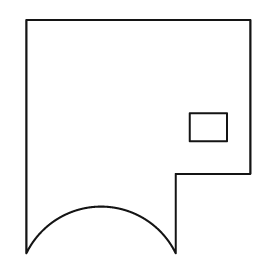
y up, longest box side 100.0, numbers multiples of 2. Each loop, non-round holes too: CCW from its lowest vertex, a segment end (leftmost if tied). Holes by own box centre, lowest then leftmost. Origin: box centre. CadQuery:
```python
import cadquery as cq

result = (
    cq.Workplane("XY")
    .moveTo(-48.0, -50.0)
    .threePointArc((-16.0, -30.0), (16.0, -50.0))
    .lineTo(16.0, -16.0)
    .lineTo(48.0, -16.0)
    .lineTo(48.0, 50.0)
    .lineTo(-48.0, 50.0)
    .close()
    .moveTo(22.0, -2.0)
    .lineTo(38.0, -2.0)
    .lineTo(38.0, 10.0)
    .lineTo(22.0, 10.0)
    .close()
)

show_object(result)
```